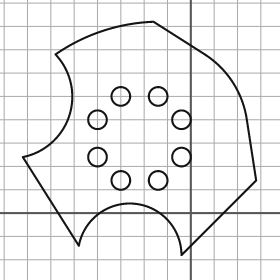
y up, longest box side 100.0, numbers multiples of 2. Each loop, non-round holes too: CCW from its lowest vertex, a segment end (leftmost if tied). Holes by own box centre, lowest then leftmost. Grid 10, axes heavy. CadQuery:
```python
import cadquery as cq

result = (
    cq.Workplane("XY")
    .moveTo(-4.0, -18.0)
    .lineTo(28.0, 14.0)
    .lineTo(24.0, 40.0)
    .threePointArc((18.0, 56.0), (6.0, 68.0))
    .lineTo(-16.0, 82.0)
    .threePointArc((-38.0, 78.0), (-58.0, 68.0))
    .threePointArc((-52.0, 42.0), (-72.0, 24.0))
    .lineTo(-48.0, -14.0)
    .threePointArc((-24.0, 4.0), (-4.0, -18.0))
    .close()
    .moveTo(-30.0, 14.0)
    .circle(4.0)
    .moveTo(-14.0, 14.0)
    .circle(4.0)
    .moveTo(-40.0, 24.0)
    .circle(4.0)
    .moveTo(-4.0, 24.0)
    .circle(4.0)
    .moveTo(-40.0, 40.0)
    .circle(4.0)
    .moveTo(-4.0, 40.0)
    .circle(4.0)
    .moveTo(-30.0, 50.0)
    .circle(4.0)
    .moveTo(-14.0, 50.0)
    .circle(4.0)
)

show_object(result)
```